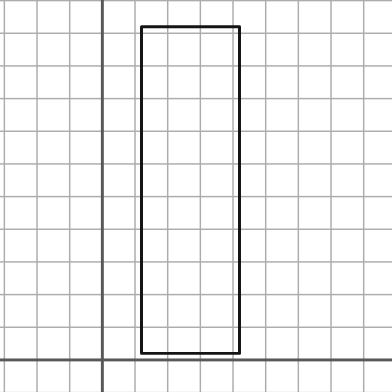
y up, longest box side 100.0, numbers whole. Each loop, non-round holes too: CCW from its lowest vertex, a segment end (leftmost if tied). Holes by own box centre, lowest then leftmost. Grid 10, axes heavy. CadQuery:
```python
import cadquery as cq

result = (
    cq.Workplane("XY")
    .moveTo(12.0, 2.0)
    .lineTo(42.0, 2.0)
    .lineTo(42.0, 102.0)
    .lineTo(12.0, 102.0)
    .close()
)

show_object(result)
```